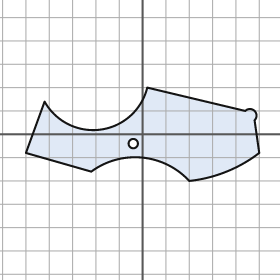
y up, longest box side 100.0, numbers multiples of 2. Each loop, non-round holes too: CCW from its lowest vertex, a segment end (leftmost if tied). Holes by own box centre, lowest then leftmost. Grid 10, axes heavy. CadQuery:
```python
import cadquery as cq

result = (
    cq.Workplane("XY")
    .moveTo(20.0, -20.0)
    .threePointArc((36.0, -16.0), (50.0, -8.0))
    .lineTo(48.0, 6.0)
    .threePointArc((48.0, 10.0), (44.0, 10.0))
    .lineTo(2.0, 20.0)
    .threePointArc((-18.0, 2.0), (-42.0, 14.0))
    .lineTo(-50.0, -8.0)
    .lineTo(-22.0, -16.0)
    .threePointArc((0.0, -10.0), (20.0, -20.0))
    .close()
    .moveTo(-4.0, -4.0)
    .circle(2.0)
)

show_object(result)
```